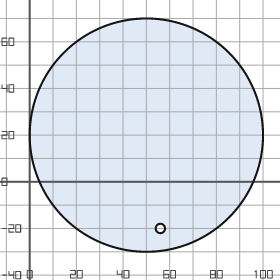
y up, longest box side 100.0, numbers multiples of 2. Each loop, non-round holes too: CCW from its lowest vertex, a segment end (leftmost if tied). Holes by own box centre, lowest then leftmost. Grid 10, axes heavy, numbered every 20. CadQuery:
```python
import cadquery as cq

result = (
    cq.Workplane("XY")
    .moveTo(50.0, 20.0)
    .circle(50.0)
    .moveTo(56.0, -20.0)
    .circle(2.0)
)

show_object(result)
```